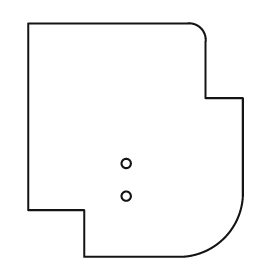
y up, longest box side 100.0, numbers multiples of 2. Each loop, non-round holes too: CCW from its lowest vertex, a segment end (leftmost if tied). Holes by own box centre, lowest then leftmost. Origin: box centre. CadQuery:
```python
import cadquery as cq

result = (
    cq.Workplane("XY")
    .moveTo(-22.0, -50.0)
    .lineTo(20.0, -50.0)
    .threePointArc((38.0, -42.0), (46.0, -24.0))
    .lineTo(46.0, 18.0)
    .lineTo(30.0, 18.0)
    .lineTo(30.0, 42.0)
    .threePointArc((28.0, 48.0), (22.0, 50.0))
    .lineTo(-46.0, 50.0)
    .lineTo(-46.0, -30.0)
    .lineTo(-22.0, -30.0)
    .close()
    .moveTo(-4.0, -24.0)
    .circle(2.0)
    .moveTo(-4.0, -10.0)
    .circle(2.0)
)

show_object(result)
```